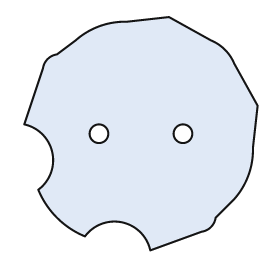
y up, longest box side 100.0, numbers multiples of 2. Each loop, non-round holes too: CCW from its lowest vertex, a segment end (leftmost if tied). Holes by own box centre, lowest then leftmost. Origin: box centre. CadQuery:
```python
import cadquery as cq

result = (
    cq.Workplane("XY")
    .moveTo(4.0, -50.0)
    .lineTo(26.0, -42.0)
    .threePointArc((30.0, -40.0), (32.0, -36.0))
    .lineTo(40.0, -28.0)
    .threePointArc((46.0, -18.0), (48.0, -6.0))
    .lineTo(50.0, 12.0)
    .lineTo(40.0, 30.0)
    .threePointArc((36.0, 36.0), (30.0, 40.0))
    .lineTo(12.0, 50.0)
    .lineTo(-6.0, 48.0)
    .threePointArc((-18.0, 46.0), (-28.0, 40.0))
    .lineTo(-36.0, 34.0)
    .threePointArc((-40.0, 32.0), (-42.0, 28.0))
    .lineTo(-50.0, 4.0)
    .threePointArc((-38.0, -8.0), (-44.0, -24.0))
    .threePointArc((-36.0, -36.0), (-24.0, -44.0))
    .threePointArc((-8.0, -38.0), (4.0, -50.0))
    .close()
    .moveTo(-18.0, 0.0)
    .circle(4.0)
    .moveTo(18.0, 0.0)
    .circle(4.0)
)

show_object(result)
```